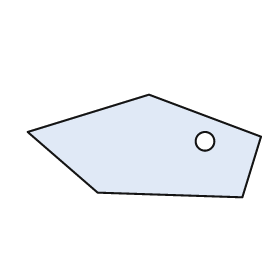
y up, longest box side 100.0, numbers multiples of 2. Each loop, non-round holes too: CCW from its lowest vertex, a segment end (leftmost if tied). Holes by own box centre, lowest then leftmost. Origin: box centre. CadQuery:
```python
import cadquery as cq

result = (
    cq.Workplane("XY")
    .moveTo(42.0, -22.0)
    .lineTo(50.0, 4.0)
    .lineTo(2.0, 22.0)
    .lineTo(-50.0, 6.0)
    .lineTo(-20.0, -20.0)
    .close()
    .moveTo(26.0, 2.0)
    .circle(4.0)
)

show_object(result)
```